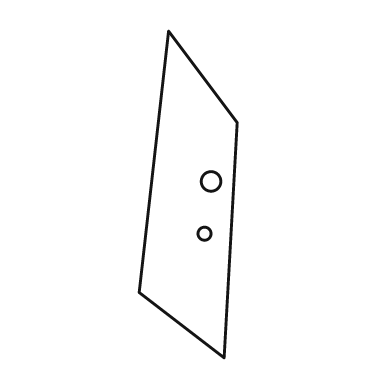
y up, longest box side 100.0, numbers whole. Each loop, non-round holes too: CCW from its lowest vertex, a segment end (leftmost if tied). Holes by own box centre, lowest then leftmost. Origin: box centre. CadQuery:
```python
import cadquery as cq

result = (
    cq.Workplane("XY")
    .moveTo(11.0, -50.0)
    .lineTo(15.0, 22.0)
    .lineTo(-6.0, 50.0)
    .lineTo(-15.0, -30.0)
    .close()
    .moveTo(5.0, -12.0)
    .circle(2.0)
    .moveTo(7.0, 4.0)
    .circle(3.0)
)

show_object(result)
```